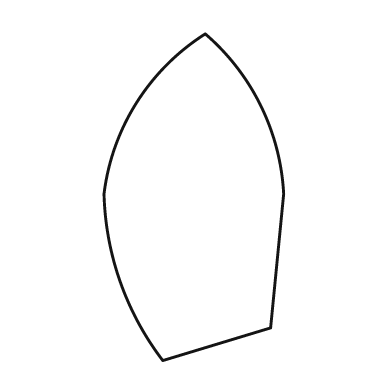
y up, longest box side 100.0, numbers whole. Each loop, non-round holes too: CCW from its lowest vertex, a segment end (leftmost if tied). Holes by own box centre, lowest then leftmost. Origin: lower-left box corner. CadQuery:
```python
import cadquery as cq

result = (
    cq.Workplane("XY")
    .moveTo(18.0, 0.0)
    .lineTo(51.0, 10.0)
    .lineTo(55.0, 51.0)
    .threePointArc((48.0, 78.0), (31.0, 100.0))
    .threePointArc((10.0, 79.0), (0.0, 51.0))
    .threePointArc((5.0, 24.0), (18.0, 0.0))
    .close()
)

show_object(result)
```